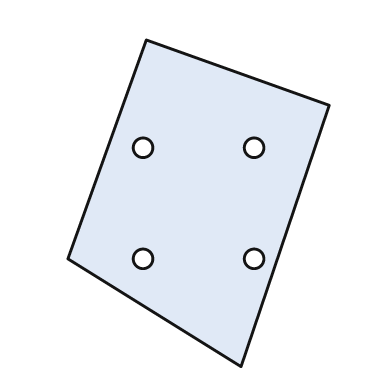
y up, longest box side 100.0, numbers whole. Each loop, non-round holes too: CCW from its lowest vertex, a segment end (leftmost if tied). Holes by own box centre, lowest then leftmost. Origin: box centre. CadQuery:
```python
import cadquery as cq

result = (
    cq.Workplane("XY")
    .moveTo(13.0, -50.0)
    .lineTo(40.0, 30.0)
    .lineTo(-16.0, 50.0)
    .lineTo(-40.0, -17.0)
    .close()
    .moveTo(-17.0, -17.0)
    .circle(3.0)
    .moveTo(17.0, -17.0)
    .circle(3.0)
    .moveTo(-17.0, 17.0)
    .circle(3.0)
    .moveTo(17.0, 17.0)
    .circle(3.0)
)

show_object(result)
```